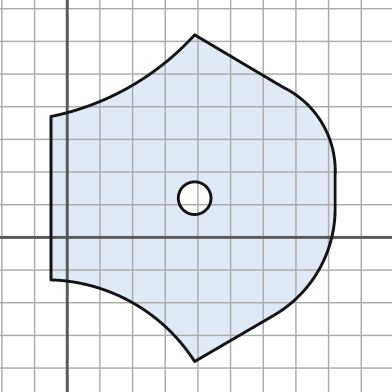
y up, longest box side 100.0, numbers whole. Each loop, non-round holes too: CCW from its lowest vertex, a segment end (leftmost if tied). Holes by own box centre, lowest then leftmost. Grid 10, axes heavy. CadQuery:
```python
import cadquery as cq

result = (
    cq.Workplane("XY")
    .moveTo(39.0, -38.0)
    .lineTo(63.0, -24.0)
    .threePointArc((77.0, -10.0), (82.0, 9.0))
    .lineTo(82.0, 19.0)
    .threePointArc((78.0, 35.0), (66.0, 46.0))
    .lineTo(39.0, 62.0)
    .threePointArc((19.0, 46.0), (-5.0, 37.0))
    .lineTo(-5.0, -13.0)
    .threePointArc((20.0, -20.0), (39.0, -38.0))
    .close()
    .moveTo(39.0, 12.0)
    .circle(5.0)
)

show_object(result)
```